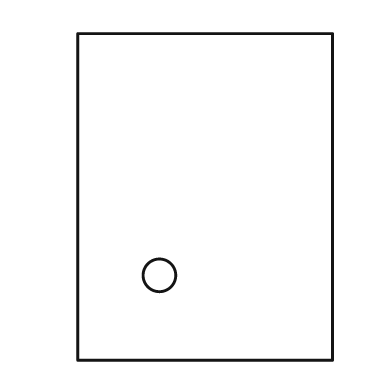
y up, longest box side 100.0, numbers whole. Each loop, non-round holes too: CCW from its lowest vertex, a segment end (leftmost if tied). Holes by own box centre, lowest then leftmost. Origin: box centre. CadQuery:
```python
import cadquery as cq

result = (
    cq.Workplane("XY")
    .moveTo(-39.0, -50.0)
    .lineTo(39.0, -50.0)
    .lineTo(39.0, 50.0)
    .lineTo(-39.0, 50.0)
    .close()
    .moveTo(-14.0, -24.0)
    .circle(5.0)
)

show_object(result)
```